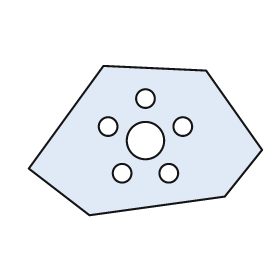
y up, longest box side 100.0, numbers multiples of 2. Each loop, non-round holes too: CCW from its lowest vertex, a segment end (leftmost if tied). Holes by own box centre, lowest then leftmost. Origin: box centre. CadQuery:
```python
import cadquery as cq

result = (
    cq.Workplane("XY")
    .moveTo(-24.0, -32.0)
    .lineTo(34.0, -24.0)
    .lineTo(50.0, -4.0)
    .lineTo(26.0, 30.0)
    .lineTo(-18.0, 32.0)
    .lineTo(-50.0, -12.0)
    .close()
    .moveTo(-10.0, -14.0)
    .circle(4.0)
    .moveTo(10.0, -14.0)
    .circle(4.0)
    .moveTo(0.0, 0.0)
    .circle(8.0)
    .moveTo(-16.0, 6.0)
    .circle(4.0)
    .moveTo(16.0, 6.0)
    .circle(4.0)
    .moveTo(0.0, 18.0)
    .circle(4.0)
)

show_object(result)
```